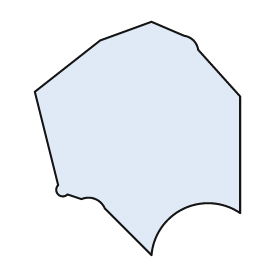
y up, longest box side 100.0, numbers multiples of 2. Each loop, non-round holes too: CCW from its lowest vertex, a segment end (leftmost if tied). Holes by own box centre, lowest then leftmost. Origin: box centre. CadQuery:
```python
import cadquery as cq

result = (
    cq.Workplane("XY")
    .moveTo(6.0, -50.0)
    .threePointArc((20.0, -30.0), (44.0, -32.0))
    .lineTo(44.0, 18.0)
    .lineTo(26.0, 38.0)
    .threePointArc((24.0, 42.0), (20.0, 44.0))
    .lineTo(6.0, 50.0)
    .lineTo(-16.0, 42.0)
    .lineTo(-44.0, 20.0)
    .lineTo(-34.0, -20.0)
    .threePointArc((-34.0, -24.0), (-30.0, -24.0))
    .lineTo(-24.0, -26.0)
    .threePointArc((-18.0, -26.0), (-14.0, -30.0))
    .close()
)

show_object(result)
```